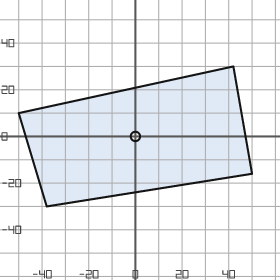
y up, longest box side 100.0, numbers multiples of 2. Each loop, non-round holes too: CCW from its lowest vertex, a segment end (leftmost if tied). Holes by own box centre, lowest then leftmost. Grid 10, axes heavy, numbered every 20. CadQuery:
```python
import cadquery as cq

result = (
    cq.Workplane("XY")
    .moveTo(-38.0, -30.0)
    .lineTo(50.0, -16.0)
    .lineTo(42.0, 30.0)
    .lineTo(-50.0, 10.0)
    .close()
    .moveTo(0.0, 0.0)
    .circle(2.0)
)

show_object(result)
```